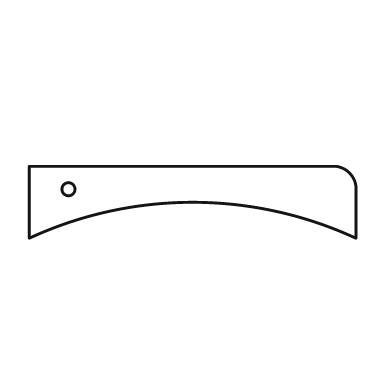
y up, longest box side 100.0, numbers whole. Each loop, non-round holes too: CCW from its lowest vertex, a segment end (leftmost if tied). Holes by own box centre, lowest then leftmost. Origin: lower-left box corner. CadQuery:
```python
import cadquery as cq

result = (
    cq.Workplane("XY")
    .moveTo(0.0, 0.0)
    .threePointArc((50.0, 11.0), (100.0, 0.0))
    .lineTo(100.0, 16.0)
    .threePointArc((98.0, 20.0), (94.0, 22.0))
    .lineTo(0.0, 22.0)
    .close()
    .moveTo(12.0, 15.0)
    .circle(2.0)
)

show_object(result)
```